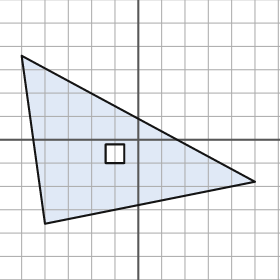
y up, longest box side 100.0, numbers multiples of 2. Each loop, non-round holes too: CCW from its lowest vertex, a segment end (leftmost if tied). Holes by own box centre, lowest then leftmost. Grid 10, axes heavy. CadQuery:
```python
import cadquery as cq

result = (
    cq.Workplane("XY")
    .moveTo(-40.0, -36.0)
    .lineTo(50.0, -18.0)
    .lineTo(-50.0, 36.0)
    .close()
    .moveTo(-14.0, -10.0)
    .lineTo(-6.0, -10.0)
    .lineTo(-6.0, -2.0)
    .lineTo(-14.0, -2.0)
    .close()
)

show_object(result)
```